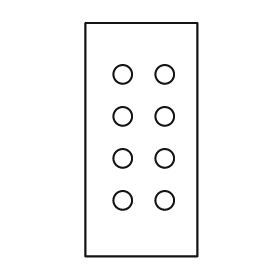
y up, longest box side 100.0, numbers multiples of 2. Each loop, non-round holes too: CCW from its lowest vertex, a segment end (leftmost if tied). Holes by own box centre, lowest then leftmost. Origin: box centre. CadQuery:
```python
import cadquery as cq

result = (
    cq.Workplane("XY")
    .moveTo(-24.0, -50.0)
    .lineTo(24.0, -50.0)
    .lineTo(24.0, 50.0)
    .lineTo(-24.0, 50.0)
    .close()
    .moveTo(-8.0, -26.0)
    .circle(4.0)
    .moveTo(10.0, -26.0)
    .circle(4.0)
    .moveTo(-8.0, -8.0)
    .circle(4.0)
    .moveTo(10.0, -8.0)
    .circle(4.0)
    .moveTo(-8.0, 10.0)
    .circle(4.0)
    .moveTo(10.0, 10.0)
    .circle(4.0)
    .moveTo(-8.0, 28.0)
    .circle(4.0)
    .moveTo(10.0, 28.0)
    .circle(4.0)
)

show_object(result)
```